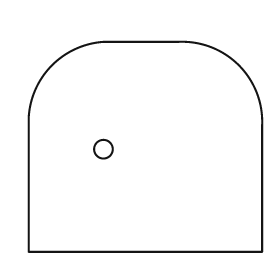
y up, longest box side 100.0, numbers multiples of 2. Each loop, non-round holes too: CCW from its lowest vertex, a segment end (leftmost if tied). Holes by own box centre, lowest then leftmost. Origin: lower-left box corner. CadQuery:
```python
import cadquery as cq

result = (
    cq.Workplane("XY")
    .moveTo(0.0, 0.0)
    .lineTo(100.0, 0.0)
    .lineTo(100.0, 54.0)
    .threePointArc((90.0, 80.0), (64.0, 90.0))
    .lineTo(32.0, 90.0)
    .threePointArc((10.0, 80.0), (0.0, 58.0))
    .close()
    .moveTo(32.0, 44.0)
    .circle(4.0)
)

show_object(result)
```